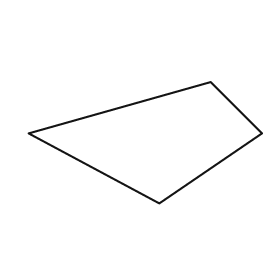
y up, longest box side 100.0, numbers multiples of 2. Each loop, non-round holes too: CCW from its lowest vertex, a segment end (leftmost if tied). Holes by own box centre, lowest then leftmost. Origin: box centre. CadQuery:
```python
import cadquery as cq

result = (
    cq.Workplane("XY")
    .moveTo(6.0, -26.0)
    .lineTo(50.0, 4.0)
    .lineTo(28.0, 26.0)
    .lineTo(-50.0, 4.0)
    .close()
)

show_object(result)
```